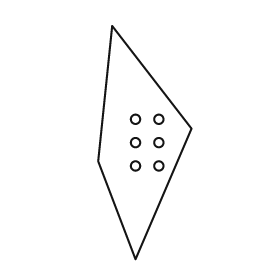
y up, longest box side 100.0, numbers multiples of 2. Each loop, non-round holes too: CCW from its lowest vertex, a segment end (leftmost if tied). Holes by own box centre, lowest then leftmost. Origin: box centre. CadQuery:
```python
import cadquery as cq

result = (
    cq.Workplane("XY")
    .moveTo(-4.0, -50.0)
    .lineTo(20.0, 6.0)
    .lineTo(-14.0, 50.0)
    .lineTo(-20.0, -8.0)
    .close()
    .moveTo(-4.0, -10.0)
    .circle(2.0)
    .moveTo(6.0, -10.0)
    .circle(2.0)
    .moveTo(-4.0, 0.0)
    .circle(2.0)
    .moveTo(6.0, 0.0)
    .circle(2.0)
    .moveTo(-4.0, 10.0)
    .circle(2.0)
    .moveTo(6.0, 10.0)
    .circle(2.0)
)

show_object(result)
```